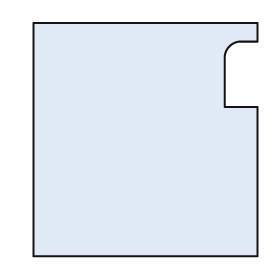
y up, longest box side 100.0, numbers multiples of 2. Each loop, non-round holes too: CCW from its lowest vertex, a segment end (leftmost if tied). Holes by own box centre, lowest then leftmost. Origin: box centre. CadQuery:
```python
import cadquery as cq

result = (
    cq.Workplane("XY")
    .moveTo(-48.0, -50.0)
    .lineTo(48.0, -50.0)
    .lineTo(48.0, 14.0)
    .lineTo(34.0, 14.0)
    .lineTo(34.0, 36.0)
    .threePointArc((36.0, 40.0), (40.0, 42.0))
    .lineTo(48.0, 42.0)
    .lineTo(48.0, 50.0)
    .lineTo(-48.0, 50.0)
    .close()
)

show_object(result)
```